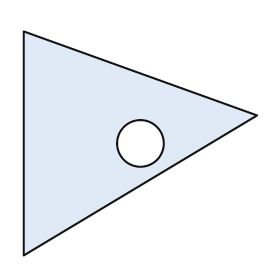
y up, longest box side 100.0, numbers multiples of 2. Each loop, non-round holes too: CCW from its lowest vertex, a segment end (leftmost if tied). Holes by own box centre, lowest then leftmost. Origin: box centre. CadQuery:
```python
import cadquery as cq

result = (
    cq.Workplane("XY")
    .moveTo(-50.0, -48.0)
    .lineTo(50.0, 12.0)
    .lineTo(-50.0, 48.0)
    .close()
    .moveTo(0.0, 0.0)
    .circle(10.0)
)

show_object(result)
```